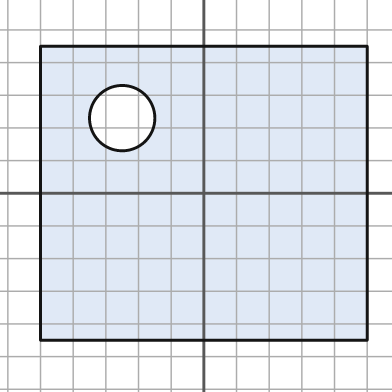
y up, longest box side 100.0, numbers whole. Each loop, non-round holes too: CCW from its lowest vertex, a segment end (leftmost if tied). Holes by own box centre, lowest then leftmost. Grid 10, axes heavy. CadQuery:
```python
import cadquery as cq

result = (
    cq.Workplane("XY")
    .moveTo(-50.0, -45.0)
    .lineTo(50.0, -45.0)
    .lineTo(50.0, 45.0)
    .lineTo(-50.0, 45.0)
    .close()
    .moveTo(-25.0, 23.0)
    .circle(10.0)
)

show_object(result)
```